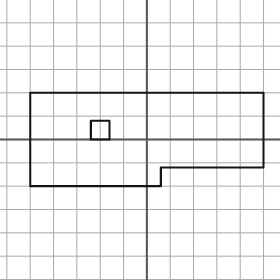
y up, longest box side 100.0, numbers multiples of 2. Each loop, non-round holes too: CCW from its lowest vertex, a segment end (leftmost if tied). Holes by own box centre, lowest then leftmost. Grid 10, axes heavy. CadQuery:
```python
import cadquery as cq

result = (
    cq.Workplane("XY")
    .moveTo(-50.0, -20.0)
    .lineTo(6.0, -20.0)
    .lineTo(6.0, -12.0)
    .lineTo(50.0, -12.0)
    .lineTo(50.0, 20.0)
    .lineTo(-50.0, 20.0)
    .close()
    .moveTo(-24.0, 0.0)
    .lineTo(-16.0, 0.0)
    .lineTo(-16.0, 8.0)
    .lineTo(-24.0, 8.0)
    .close()
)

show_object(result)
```